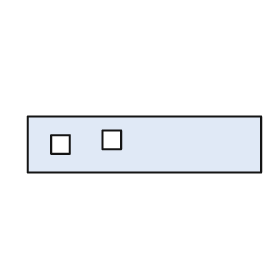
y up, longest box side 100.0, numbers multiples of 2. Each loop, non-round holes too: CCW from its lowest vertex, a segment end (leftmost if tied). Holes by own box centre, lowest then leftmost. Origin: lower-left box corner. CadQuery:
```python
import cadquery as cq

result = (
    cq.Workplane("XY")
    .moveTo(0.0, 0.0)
    .lineTo(100.0, 0.0)
    .lineTo(100.0, 24.0)
    .lineTo(0.0, 24.0)
    .close()
    .moveTo(10.0, 8.0)
    .lineTo(18.0, 8.0)
    .lineTo(18.0, 16.0)
    .lineTo(10.0, 16.0)
    .close()
    .moveTo(32.0, 10.0)
    .lineTo(40.0, 10.0)
    .lineTo(40.0, 18.0)
    .lineTo(32.0, 18.0)
    .close()
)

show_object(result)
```